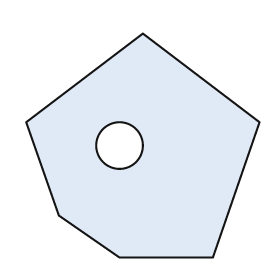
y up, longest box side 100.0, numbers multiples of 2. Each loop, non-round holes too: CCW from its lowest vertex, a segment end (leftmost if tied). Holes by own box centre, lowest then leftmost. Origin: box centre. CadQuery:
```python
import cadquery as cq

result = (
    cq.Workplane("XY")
    .moveTo(-10.0, -48.0)
    .lineTo(30.0, -48.0)
    .lineTo(50.0, 10.0)
    .lineTo(0.0, 48.0)
    .lineTo(-50.0, 10.0)
    .lineTo(-36.0, -30.0)
    .close()
    .moveTo(-10.0, 0.0)
    .circle(10.0)
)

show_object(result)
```